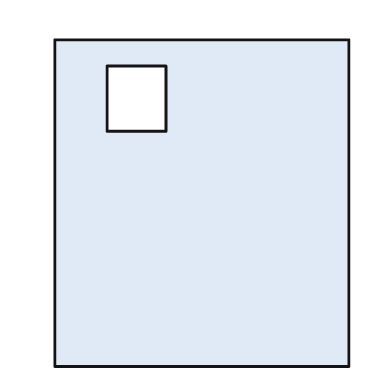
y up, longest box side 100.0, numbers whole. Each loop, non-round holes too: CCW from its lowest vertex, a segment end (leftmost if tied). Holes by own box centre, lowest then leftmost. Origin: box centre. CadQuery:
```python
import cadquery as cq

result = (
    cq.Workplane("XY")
    .moveTo(-45.0, -50.0)
    .lineTo(45.0, -50.0)
    .lineTo(45.0, 50.0)
    .lineTo(-45.0, 50.0)
    .close()
    .moveTo(-29.0, 22.0)
    .lineTo(-11.0, 22.0)
    .lineTo(-11.0, 42.0)
    .lineTo(-29.0, 42.0)
    .close()
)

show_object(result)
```